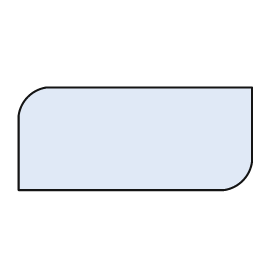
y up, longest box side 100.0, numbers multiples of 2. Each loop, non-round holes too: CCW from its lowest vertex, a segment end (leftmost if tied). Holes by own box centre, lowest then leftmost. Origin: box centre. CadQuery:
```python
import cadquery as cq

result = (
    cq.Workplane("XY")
    .moveTo(-50.0, -22.0)
    .lineTo(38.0, -22.0)
    .threePointArc((46.0, -18.0), (50.0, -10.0))
    .lineTo(50.0, 22.0)
    .lineTo(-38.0, 22.0)
    .threePointArc((-46.0, 18.0), (-50.0, 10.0))
    .close()
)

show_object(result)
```